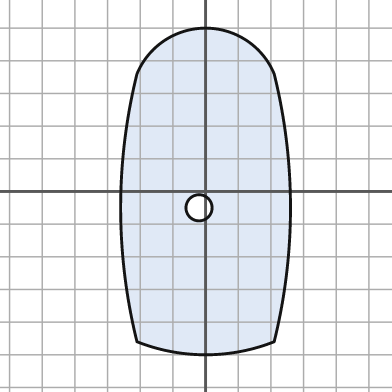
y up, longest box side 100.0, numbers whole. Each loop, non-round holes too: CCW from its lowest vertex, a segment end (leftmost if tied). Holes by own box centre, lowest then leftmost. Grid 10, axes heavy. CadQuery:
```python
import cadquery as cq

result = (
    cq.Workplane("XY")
    .moveTo(-21.0, -46.0)
    .threePointArc((0.0, -50.0), (21.0, -46.0))
    .threePointArc((26.0, -5.0), (21.0, 36.0))
    .threePointArc((0.0, 50.0), (-21.0, 36.0))
    .threePointArc((-26.0, -5.0), (-21.0, -46.0))
    .close()
    .moveTo(-2.0, -5.0)
    .circle(4.0)
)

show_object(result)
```